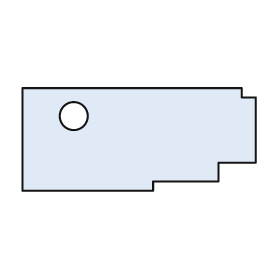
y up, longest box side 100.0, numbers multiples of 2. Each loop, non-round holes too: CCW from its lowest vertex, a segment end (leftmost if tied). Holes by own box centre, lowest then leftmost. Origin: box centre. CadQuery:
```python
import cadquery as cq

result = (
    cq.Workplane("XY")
    .moveTo(-50.0, -22.0)
    .lineTo(6.0, -22.0)
    .lineTo(6.0, -18.0)
    .lineTo(34.0, -18.0)
    .lineTo(34.0, -10.0)
    .lineTo(50.0, -10.0)
    .lineTo(50.0, 18.0)
    .lineTo(44.0, 18.0)
    .lineTo(44.0, 22.0)
    .lineTo(-50.0, 22.0)
    .close()
    .moveTo(-28.0, 10.0)
    .circle(6.0)
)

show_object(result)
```